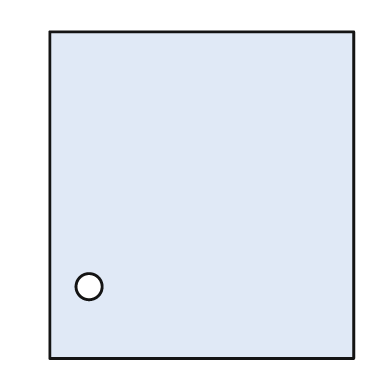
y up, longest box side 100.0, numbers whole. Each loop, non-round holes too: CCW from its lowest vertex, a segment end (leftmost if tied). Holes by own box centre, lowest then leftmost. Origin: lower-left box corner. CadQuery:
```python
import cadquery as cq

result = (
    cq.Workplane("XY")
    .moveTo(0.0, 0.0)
    .lineTo(93.0, 0.0)
    .lineTo(93.0, 100.0)
    .lineTo(0.0, 100.0)
    .close()
    .moveTo(12.0, 22.0)
    .circle(4.0)
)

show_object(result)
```